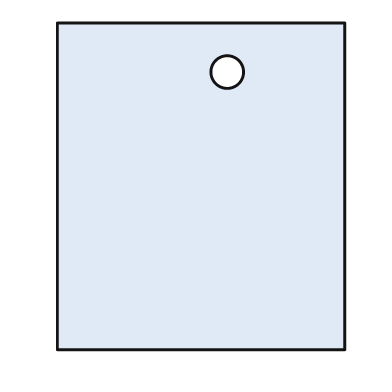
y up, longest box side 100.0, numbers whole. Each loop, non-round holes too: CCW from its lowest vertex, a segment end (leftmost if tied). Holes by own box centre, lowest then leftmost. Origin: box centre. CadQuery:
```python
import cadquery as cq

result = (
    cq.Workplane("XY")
    .moveTo(-44.0, -50.0)
    .lineTo(44.0, -50.0)
    .lineTo(44.0, 50.0)
    .lineTo(-44.0, 50.0)
    .close()
    .moveTo(8.0, 35.0)
    .circle(5.0)
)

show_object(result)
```